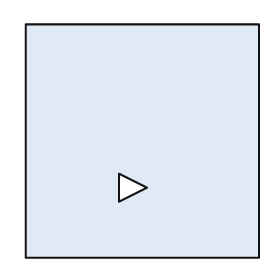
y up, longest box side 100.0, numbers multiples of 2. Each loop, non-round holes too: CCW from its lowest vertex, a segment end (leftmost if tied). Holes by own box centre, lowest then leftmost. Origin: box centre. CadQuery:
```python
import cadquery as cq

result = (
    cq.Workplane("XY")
    .moveTo(-50.0, -50.0)
    .lineTo(50.0, -50.0)
    .lineTo(50.0, 50.0)
    .lineTo(-50.0, 50.0)
    .close()
    .moveTo(-10.0, -26.0)
    .lineTo(2.0, -20.0)
    .lineTo(-10.0, -14.0)
    .close()
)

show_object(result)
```